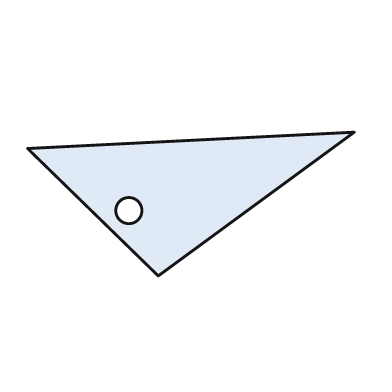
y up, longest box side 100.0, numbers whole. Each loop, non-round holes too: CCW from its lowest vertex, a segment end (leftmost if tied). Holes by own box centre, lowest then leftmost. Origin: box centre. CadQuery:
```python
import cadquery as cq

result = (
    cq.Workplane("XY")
    .moveTo(-10.0, -22.0)
    .lineTo(50.0, 22.0)
    .lineTo(-50.0, 17.0)
    .close()
    .moveTo(-19.0, -2.0)
    .circle(4.0)
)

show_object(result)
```